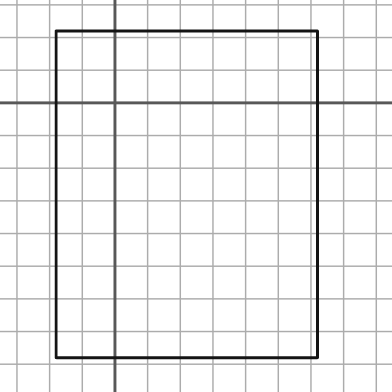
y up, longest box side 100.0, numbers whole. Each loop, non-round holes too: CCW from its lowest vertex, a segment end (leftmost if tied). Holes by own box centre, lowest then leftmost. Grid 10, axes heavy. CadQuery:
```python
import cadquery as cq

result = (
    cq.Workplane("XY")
    .moveTo(-18.0, -78.0)
    .lineTo(62.0, -78.0)
    .lineTo(62.0, 22.0)
    .lineTo(-18.0, 22.0)
    .close()
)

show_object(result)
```